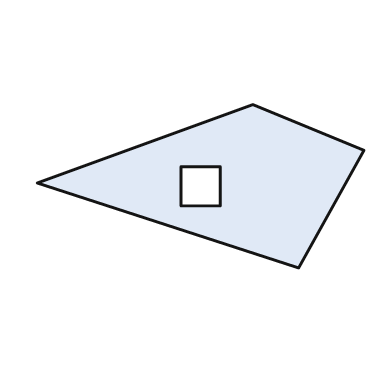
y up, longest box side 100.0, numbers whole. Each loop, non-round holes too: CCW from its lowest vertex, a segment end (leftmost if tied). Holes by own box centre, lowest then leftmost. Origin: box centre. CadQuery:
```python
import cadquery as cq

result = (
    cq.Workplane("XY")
    .moveTo(30.0, -25.0)
    .lineTo(50.0, 11.0)
    .lineTo(16.0, 25.0)
    .lineTo(-50.0, 1.0)
    .close()
    .moveTo(-6.0, -6.0)
    .lineTo(6.0, -6.0)
    .lineTo(6.0, 6.0)
    .lineTo(-6.0, 6.0)
    .close()
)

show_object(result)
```